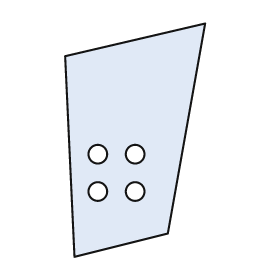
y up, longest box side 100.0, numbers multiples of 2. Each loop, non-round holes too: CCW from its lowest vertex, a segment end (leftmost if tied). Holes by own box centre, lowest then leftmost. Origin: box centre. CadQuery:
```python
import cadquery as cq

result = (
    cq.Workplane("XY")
    .moveTo(-26.0, -50.0)
    .lineTo(14.0, -40.0)
    .lineTo(30.0, 50.0)
    .lineTo(-30.0, 36.0)
    .close()
    .moveTo(-16.0, -22.0)
    .circle(4.0)
    .moveTo(0.0, -22.0)
    .circle(4.0)
    .moveTo(-16.0, -6.0)
    .circle(4.0)
    .moveTo(0.0, -6.0)
    .circle(4.0)
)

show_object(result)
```